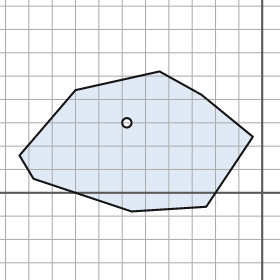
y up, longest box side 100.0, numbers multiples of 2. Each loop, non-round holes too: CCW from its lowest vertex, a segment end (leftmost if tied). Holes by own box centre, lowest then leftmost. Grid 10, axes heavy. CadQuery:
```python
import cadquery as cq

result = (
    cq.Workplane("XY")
    .moveTo(-56.0, -8.0)
    .lineTo(-24.0, -6.0)
    .lineTo(-4.0, 24.0)
    .lineTo(-26.0, 42.0)
    .lineTo(-44.0, 52.0)
    .lineTo(-80.0, 44.0)
    .lineTo(-104.0, 16.0)
    .lineTo(-98.0, 6.0)
    .close()
    .moveTo(-58.0, 30.0)
    .circle(2.0)
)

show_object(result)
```